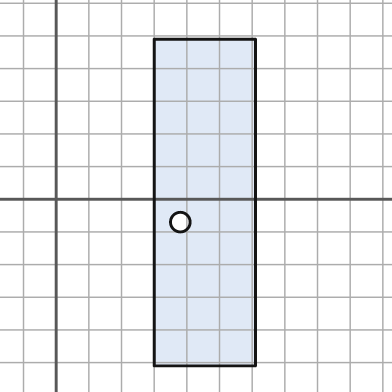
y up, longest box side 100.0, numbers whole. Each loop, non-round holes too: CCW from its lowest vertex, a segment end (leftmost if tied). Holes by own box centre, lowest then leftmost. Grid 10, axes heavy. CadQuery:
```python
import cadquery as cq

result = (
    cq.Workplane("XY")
    .moveTo(30.0, -51.0)
    .lineTo(61.0, -51.0)
    .lineTo(61.0, 49.0)
    .lineTo(30.0, 49.0)
    .close()
    .moveTo(38.0, -7.0)
    .circle(3.0)
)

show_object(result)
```